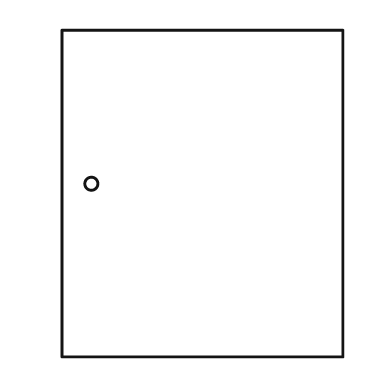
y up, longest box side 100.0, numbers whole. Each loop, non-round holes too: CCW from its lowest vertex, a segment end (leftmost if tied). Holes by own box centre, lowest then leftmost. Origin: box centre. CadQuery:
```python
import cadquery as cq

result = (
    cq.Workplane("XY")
    .moveTo(-43.0, -50.0)
    .lineTo(43.0, -50.0)
    .lineTo(43.0, 50.0)
    .lineTo(-43.0, 50.0)
    .close()
    .moveTo(-34.0, 3.0)
    .circle(2.0)
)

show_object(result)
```